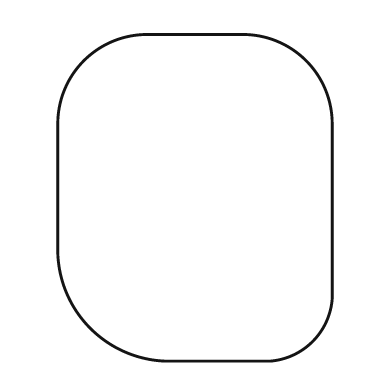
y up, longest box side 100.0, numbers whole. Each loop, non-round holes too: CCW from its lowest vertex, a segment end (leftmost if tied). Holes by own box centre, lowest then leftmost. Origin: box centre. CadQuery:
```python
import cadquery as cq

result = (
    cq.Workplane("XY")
    .moveTo(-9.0, -50.0)
    .lineTo(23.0, -50.0)
    .threePointArc((36.0, -44.0), (42.0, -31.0))
    .lineTo(42.0, 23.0)
    .threePointArc((34.0, 42.0), (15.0, 50.0))
    .lineTo(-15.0, 50.0)
    .threePointArc((-34.0, 42.0), (-42.0, 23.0))
    .lineTo(-42.0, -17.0)
    .threePointArc((-32.0, -40.0), (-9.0, -50.0))
    .close()
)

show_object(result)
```